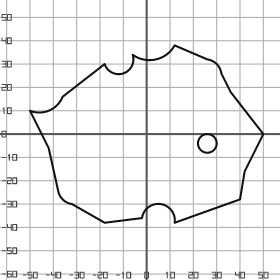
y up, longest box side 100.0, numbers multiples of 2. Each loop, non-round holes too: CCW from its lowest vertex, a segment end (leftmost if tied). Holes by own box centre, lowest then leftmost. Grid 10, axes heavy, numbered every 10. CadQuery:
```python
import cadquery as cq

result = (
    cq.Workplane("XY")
    .moveTo(-18.0, -38.0)
    .lineTo(-2.0, -36.0)
    .threePointArc((6.0, -30.0), (12.0, -38.0))
    .lineTo(40.0, -28.0)
    .lineTo(42.0, -16.0)
    .lineTo(50.0, 0.0)
    .lineTo(36.0, 18.0)
    .lineTo(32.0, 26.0)
    .threePointArc((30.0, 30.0), (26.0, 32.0))
    .lineTo(12.0, 38.0)
    .threePointArc((4.0, 32.0), (-6.0, 34.0))
    .threePointArc((-10.0, 26.0), (-18.0, 30.0))
    .lineTo(-36.0, 16.0)
    .threePointArc((-42.0, 10.0), (-50.0, 10.0))
    .lineTo(-42.0, -6.0)
    .lineTo(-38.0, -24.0)
    .threePointArc((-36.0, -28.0), (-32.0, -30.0))
    .close()
    .moveTo(26.0, -4.0)
    .circle(4.0)
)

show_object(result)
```